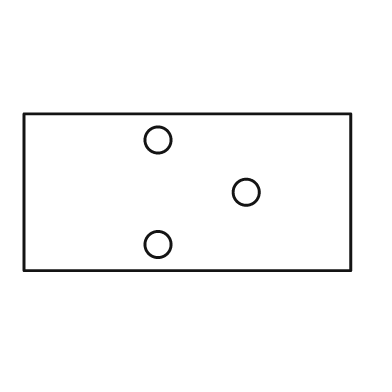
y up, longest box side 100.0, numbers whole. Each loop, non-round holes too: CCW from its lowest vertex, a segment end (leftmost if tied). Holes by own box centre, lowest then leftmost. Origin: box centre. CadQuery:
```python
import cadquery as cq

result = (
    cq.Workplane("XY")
    .moveTo(-50.0, -24.0)
    .lineTo(50.0, -24.0)
    .lineTo(50.0, 24.0)
    .lineTo(-50.0, 24.0)
    .close()
    .moveTo(-9.0, -16.0)
    .circle(4.0)
    .moveTo(18.0, 0.0)
    .circle(4.0)
    .moveTo(-9.0, 16.0)
    .circle(4.0)
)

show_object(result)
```